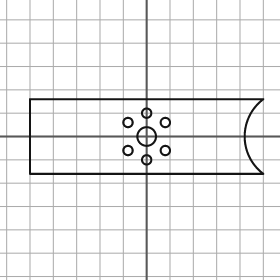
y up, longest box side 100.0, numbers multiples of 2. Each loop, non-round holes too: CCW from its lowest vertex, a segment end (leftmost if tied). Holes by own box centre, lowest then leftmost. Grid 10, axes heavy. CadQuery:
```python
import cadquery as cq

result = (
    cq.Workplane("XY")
    .moveTo(-50.0, -16.0)
    .lineTo(50.0, -16.0)
    .threePointArc((42.0, 0.0), (50.0, 16.0))
    .lineTo(-50.0, 16.0)
    .close()
    .moveTo(0.0, -10.0)
    .circle(2.0)
    .moveTo(-8.0, -6.0)
    .circle(2.0)
    .moveTo(8.0, -6.0)
    .circle(2.0)
    .moveTo(0.0, 0.0)
    .circle(4.0)
    .moveTo(-8.0, 6.0)
    .circle(2.0)
    .moveTo(8.0, 6.0)
    .circle(2.0)
    .moveTo(0.0, 10.0)
    .circle(2.0)
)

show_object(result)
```